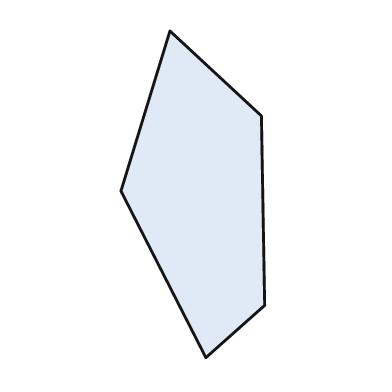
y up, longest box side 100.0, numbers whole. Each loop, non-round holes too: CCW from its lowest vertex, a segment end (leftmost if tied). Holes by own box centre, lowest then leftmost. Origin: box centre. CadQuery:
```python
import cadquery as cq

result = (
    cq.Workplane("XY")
    .moveTo(4.0, -50.0)
    .lineTo(22.0, -34.0)
    .lineTo(21.0, 24.0)
    .lineTo(-7.0, 50.0)
    .lineTo(-22.0, 1.0)
    .close()
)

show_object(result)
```